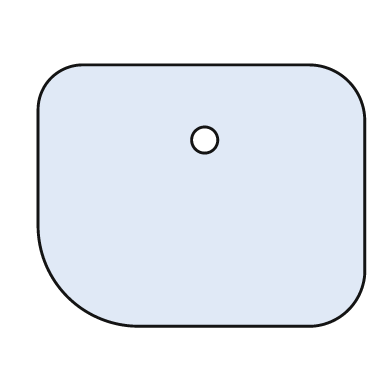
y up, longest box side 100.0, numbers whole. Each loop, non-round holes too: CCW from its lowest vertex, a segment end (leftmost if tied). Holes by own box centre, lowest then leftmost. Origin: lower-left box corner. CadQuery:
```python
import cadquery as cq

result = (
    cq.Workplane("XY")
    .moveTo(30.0, 0.0)
    .lineTo(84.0, 0.0)
    .threePointArc((95.0, 5.0), (100.0, 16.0))
    .lineTo(100.0, 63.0)
    .threePointArc((95.0, 75.0), (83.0, 80.0))
    .lineTo(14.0, 80.0)
    .threePointArc((4.0, 76.0), (0.0, 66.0))
    .lineTo(0.0, 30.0)
    .threePointArc((9.0, 9.0), (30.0, 0.0))
    .close()
    .moveTo(51.0, 57.0)
    .circle(4.0)
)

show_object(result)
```